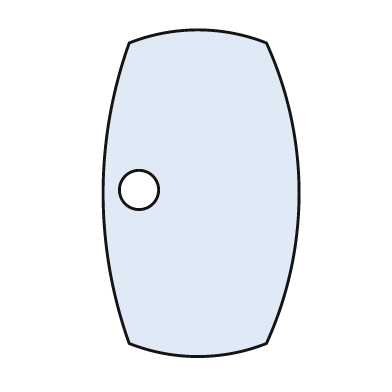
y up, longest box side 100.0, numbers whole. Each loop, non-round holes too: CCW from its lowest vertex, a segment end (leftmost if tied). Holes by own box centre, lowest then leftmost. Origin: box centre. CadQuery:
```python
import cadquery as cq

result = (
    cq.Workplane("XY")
    .moveTo(-22.0, -46.0)
    .threePointArc((-1.0, -50.0), (20.0, -46.0))
    .threePointArc((30.0, 0.0), (20.0, 46.0))
    .threePointArc((-1.0, 50.0), (-22.0, 46.0))
    .threePointArc((-30.0, 0.0), (-22.0, -46.0))
    .close()
    .moveTo(-19.0, 1.0)
    .circle(6.0)
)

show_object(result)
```